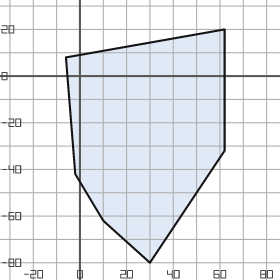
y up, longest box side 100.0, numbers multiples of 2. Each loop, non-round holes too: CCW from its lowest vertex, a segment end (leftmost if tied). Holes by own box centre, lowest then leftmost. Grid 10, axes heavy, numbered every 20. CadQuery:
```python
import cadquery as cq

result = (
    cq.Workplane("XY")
    .moveTo(30.0, -80.0)
    .lineTo(62.0, -32.0)
    .lineTo(62.0, 20.0)
    .lineTo(-6.0, 8.0)
    .lineTo(-2.0, -42.0)
    .lineTo(10.0, -62.0)
    .close()
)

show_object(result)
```